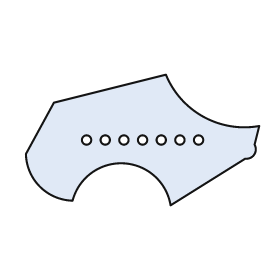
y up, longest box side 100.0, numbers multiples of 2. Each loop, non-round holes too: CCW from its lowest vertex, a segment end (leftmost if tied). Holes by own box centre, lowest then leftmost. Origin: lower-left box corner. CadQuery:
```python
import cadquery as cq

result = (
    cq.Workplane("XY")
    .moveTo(62.0, 0.0)
    .lineTo(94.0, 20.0)
    .threePointArc((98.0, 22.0), (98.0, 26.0))
    .lineTo(100.0, 34.0)
    .threePointArc((76.0, 38.0), (60.0, 56.0))
    .lineTo(12.0, 44.0)
    .lineTo(0.0, 22.0)
    .threePointArc((6.0, 8.0), (20.0, 2.0))
    .threePointArc((42.0, 18.0), (62.0, 0.0))
    .close()
    .moveTo(26.0, 28.0)
    .circle(2.0)
    .moveTo(34.0, 28.0)
    .circle(2.0)
    .moveTo(42.0, 28.0)
    .circle(2.0)
    .moveTo(50.0, 28.0)
    .circle(2.0)
    .moveTo(58.0, 28.0)
    .circle(2.0)
    .moveTo(66.0, 28.0)
    .circle(2.0)
    .moveTo(74.0, 28.0)
    .circle(2.0)
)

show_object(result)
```